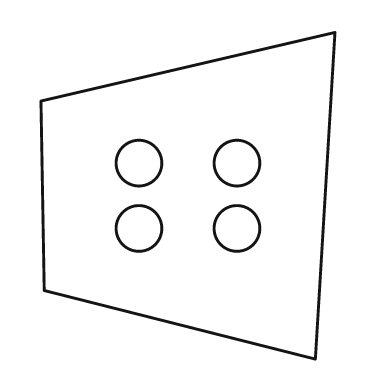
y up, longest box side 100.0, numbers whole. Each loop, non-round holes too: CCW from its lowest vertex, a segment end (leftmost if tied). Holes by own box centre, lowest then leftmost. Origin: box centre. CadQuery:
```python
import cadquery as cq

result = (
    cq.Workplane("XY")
    .moveTo(39.0, -50.0)
    .lineTo(45.0, 50.0)
    .lineTo(-45.0, 29.0)
    .lineTo(-44.0, -29.0)
    .close()
    .moveTo(-15.0, -10.0)
    .circle(7.0)
    .moveTo(15.0, -10.0)
    .circle(7.0)
    .moveTo(-15.0, 10.0)
    .circle(7.0)
    .moveTo(15.0, 10.0)
    .circle(7.0)
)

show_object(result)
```